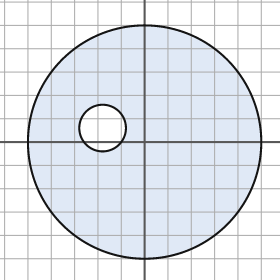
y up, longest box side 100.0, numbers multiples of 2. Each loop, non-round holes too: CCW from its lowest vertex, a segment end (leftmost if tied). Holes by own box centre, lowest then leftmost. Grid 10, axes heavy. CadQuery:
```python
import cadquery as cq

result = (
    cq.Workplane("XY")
    .moveTo(0.0, 0.0)
    .circle(50.0)
    .moveTo(-18.0, 6.0)
    .circle(10.0)
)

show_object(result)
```